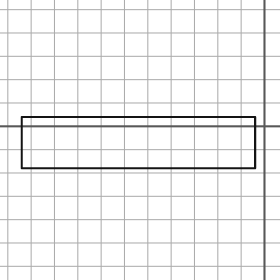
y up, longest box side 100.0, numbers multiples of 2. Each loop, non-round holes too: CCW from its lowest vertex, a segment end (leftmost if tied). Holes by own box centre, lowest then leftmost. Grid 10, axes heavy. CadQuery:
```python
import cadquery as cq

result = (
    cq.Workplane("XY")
    .moveTo(-104.0, -18.0)
    .lineTo(-4.0, -18.0)
    .lineTo(-4.0, 4.0)
    .lineTo(-104.0, 4.0)
    .close()
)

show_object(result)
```